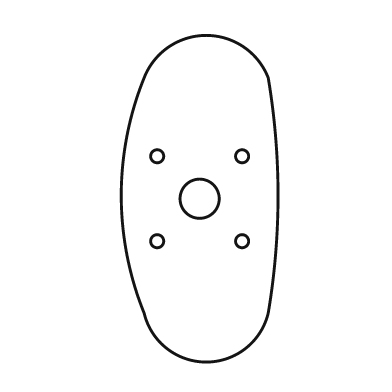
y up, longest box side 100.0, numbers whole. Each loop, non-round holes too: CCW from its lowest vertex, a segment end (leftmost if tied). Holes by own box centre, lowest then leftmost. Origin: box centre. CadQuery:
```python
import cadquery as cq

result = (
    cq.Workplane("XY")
    .moveTo(-17.0, -35.0)
    .threePointArc((2.0, -50.0), (21.0, -35.0))
    .threePointArc((24.0, 1.0), (21.0, 37.0))
    .threePointArc((2.0, 50.0), (-17.0, 37.0))
    .threePointArc((-24.0, 1.0), (-17.0, -35.0))
    .close()
    .moveTo(-13.0, -13.0)
    .circle(2.0)
    .moveTo(13.0, -13.0)
    .circle(2.0)
    .moveTo(0.0, 0.0)
    .circle(6.0)
    .moveTo(-13.0, 13.0)
    .circle(2.0)
    .moveTo(13.0, 13.0)
    .circle(2.0)
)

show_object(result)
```